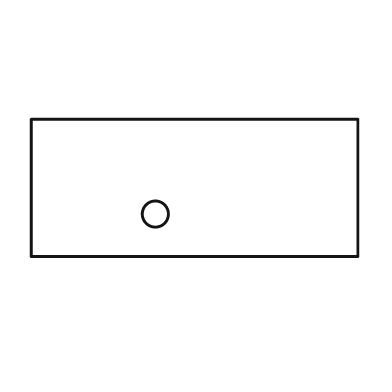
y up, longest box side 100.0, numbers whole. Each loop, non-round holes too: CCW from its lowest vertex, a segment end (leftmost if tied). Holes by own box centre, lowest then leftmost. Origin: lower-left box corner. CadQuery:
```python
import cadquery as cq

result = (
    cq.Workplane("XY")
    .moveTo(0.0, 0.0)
    .lineTo(100.0, 0.0)
    .lineTo(100.0, 42.0)
    .lineTo(0.0, 42.0)
    .close()
    .moveTo(38.0, 13.0)
    .circle(4.0)
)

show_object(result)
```